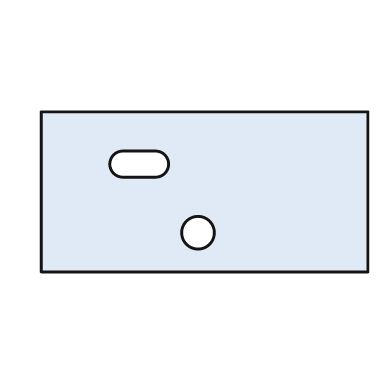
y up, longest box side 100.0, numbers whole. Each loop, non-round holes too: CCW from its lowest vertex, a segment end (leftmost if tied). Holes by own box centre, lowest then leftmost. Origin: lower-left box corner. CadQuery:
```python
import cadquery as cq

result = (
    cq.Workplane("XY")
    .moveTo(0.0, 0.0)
    .lineTo(100.0, 0.0)
    .lineTo(100.0, 49.0)
    .lineTo(0.0, 49.0)
    .close()
    .moveTo(48.0, 12.0)
    .circle(5.0)
    .moveTo(25.0, 29.0)
    .lineTo(35.0, 29.0)
    .threePointArc((39.0, 33.0), (35.0, 37.0))
    .lineTo(25.0, 37.0)
    .threePointArc((21.0, 33.0), (25.0, 29.0))
    .close()
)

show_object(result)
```